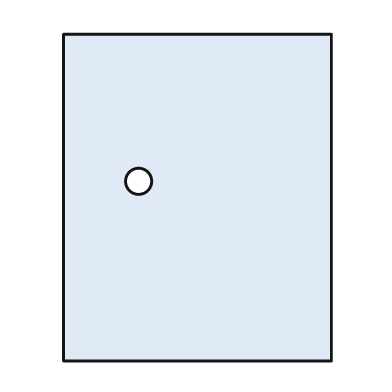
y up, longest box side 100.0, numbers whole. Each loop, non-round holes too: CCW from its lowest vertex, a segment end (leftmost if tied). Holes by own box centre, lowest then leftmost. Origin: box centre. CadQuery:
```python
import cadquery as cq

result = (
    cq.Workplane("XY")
    .moveTo(-41.0, -50.0)
    .lineTo(41.0, -50.0)
    .lineTo(41.0, 50.0)
    .lineTo(-41.0, 50.0)
    .close()
    .moveTo(-18.0, 5.0)
    .circle(4.0)
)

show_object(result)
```